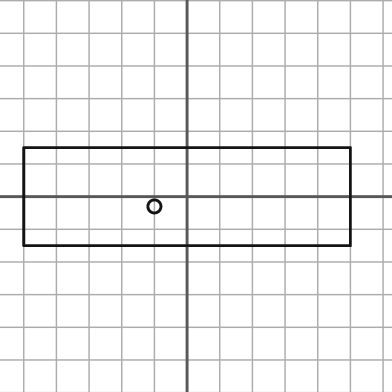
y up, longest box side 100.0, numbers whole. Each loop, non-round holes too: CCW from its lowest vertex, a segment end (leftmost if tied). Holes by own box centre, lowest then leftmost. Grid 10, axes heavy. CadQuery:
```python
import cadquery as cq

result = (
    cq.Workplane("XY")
    .moveTo(-50.0, -15.0)
    .lineTo(50.0, -15.0)
    .lineTo(50.0, 15.0)
    .lineTo(-50.0, 15.0)
    .close()
    .moveTo(-10.0, -3.0)
    .circle(2.0)
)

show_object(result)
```